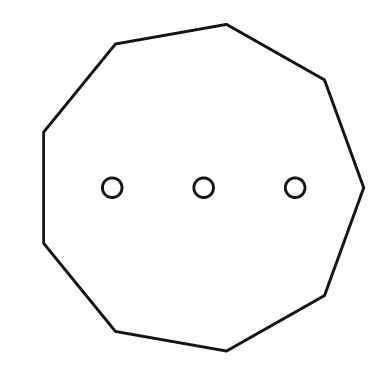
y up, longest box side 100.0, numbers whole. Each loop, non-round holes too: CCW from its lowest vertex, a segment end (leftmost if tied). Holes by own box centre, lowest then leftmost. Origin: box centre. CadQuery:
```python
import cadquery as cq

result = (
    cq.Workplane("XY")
    .moveTo(7.0, -50.0)
    .lineTo(37.0, -33.0)
    .lineTo(49.0, 0.0)
    .lineTo(37.0, 33.0)
    .lineTo(7.0, 50.0)
    .lineTo(-27.0, 44.0)
    .lineTo(-49.0, 17.0)
    .lineTo(-49.0, -17.0)
    .lineTo(-27.0, -44.0)
    .close()
    .moveTo(-28.0, 0.0)
    .circle(3.0)
    .moveTo(0.0, 0.0)
    .circle(3.0)
    .moveTo(28.0, 0.0)
    .circle(3.0)
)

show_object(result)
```